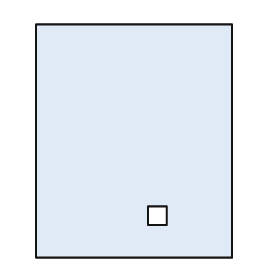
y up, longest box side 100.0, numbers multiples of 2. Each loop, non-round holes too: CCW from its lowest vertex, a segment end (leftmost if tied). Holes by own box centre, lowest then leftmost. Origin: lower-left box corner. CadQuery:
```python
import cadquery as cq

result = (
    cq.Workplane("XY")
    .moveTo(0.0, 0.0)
    .lineTo(84.0, 0.0)
    .lineTo(84.0, 100.0)
    .lineTo(0.0, 100.0)
    .close()
    .moveTo(48.0, 14.0)
    .lineTo(56.0, 14.0)
    .lineTo(56.0, 22.0)
    .lineTo(48.0, 22.0)
    .close()
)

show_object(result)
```